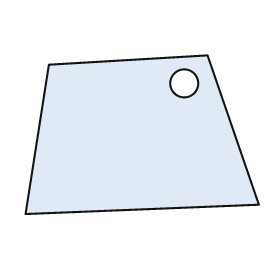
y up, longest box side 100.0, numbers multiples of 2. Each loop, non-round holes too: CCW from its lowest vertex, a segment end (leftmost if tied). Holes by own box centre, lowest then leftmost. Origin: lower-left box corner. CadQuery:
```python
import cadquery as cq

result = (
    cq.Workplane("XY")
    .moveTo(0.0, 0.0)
    .lineTo(100.0, 4.0)
    .lineTo(78.0, 68.0)
    .lineTo(10.0, 64.0)
    .close()
    .moveTo(68.0, 56.0)
    .circle(6.0)
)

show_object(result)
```